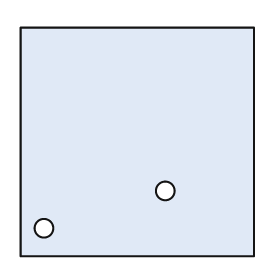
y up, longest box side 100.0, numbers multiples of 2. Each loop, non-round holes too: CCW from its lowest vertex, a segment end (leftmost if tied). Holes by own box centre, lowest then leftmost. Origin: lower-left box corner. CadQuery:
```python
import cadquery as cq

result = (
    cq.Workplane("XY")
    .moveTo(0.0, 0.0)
    .lineTo(100.0, 0.0)
    .lineTo(100.0, 98.0)
    .lineTo(0.0, 98.0)
    .close()
    .moveTo(10.0, 12.0)
    .circle(4.0)
    .moveTo(62.0, 28.0)
    .circle(4.0)
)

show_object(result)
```